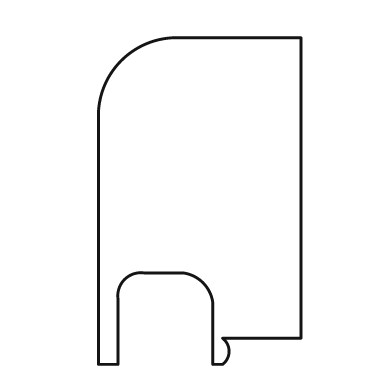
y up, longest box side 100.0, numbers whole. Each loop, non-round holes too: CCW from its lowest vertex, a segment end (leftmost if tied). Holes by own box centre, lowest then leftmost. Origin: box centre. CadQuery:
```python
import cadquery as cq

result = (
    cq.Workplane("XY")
    .moveTo(-31.0, -50.0)
    .lineTo(-25.0, -50.0)
    .lineTo(-25.0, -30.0)
    .threePointArc((-23.0, -24.0), (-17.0, -22.0))
    .lineTo(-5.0, -22.0)
    .threePointArc((1.0, -25.0), (4.0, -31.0))
    .lineTo(4.0, -50.0)
    .lineTo(7.0, -50.0)
    .threePointArc((9.0, -46.0), (7.0, -42.0))
    .lineTo(31.0, -42.0)
    .lineTo(31.0, 50.0)
    .lineTo(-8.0, 50.0)
    .threePointArc((-24.0, 43.0), (-31.0, 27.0))
    .close()
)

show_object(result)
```